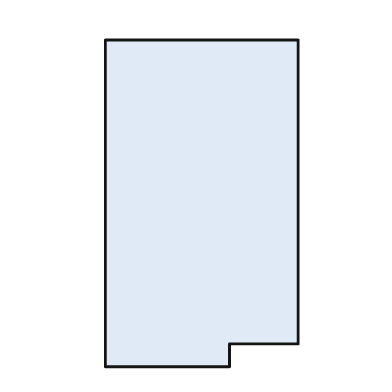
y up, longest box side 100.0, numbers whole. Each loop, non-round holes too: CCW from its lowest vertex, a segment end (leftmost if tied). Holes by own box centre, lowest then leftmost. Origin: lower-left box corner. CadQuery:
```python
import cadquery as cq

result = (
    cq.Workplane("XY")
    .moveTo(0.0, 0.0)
    .lineTo(38.0, 0.0)
    .lineTo(38.0, 7.0)
    .lineTo(59.0, 7.0)
    .lineTo(59.0, 100.0)
    .lineTo(0.0, 100.0)
    .close()
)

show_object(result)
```